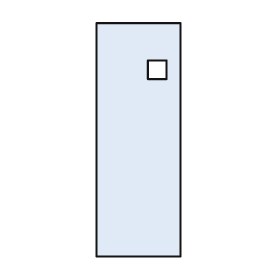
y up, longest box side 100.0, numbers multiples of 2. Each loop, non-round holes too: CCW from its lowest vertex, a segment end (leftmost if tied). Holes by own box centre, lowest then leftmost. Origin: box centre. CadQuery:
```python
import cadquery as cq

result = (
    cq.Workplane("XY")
    .moveTo(-18.0, -50.0)
    .lineTo(18.0, -50.0)
    .lineTo(18.0, 50.0)
    .lineTo(-18.0, 50.0)
    .close()
    .moveTo(4.0, 26.0)
    .lineTo(12.0, 26.0)
    .lineTo(12.0, 34.0)
    .lineTo(4.0, 34.0)
    .close()
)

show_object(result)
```